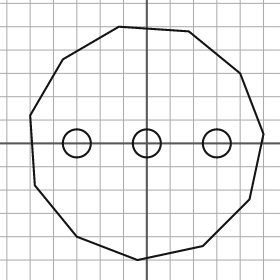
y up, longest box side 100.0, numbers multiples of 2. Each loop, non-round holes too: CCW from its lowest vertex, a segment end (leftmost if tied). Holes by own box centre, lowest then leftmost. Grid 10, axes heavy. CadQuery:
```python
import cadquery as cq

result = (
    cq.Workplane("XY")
    .moveTo(-4.0, -50.0)
    .lineTo(24.0, -44.0)
    .lineTo(44.0, -24.0)
    .lineTo(50.0, 4.0)
    .lineTo(40.0, 30.0)
    .lineTo(18.0, 48.0)
    .lineTo(-12.0, 50.0)
    .lineTo(-36.0, 36.0)
    .lineTo(-50.0, 12.0)
    .lineTo(-48.0, -18.0)
    .lineTo(-30.0, -40.0)
    .close()
    .moveTo(-30.0, 0.0)
    .circle(6.0)
    .moveTo(0.0, 0.0)
    .circle(6.0)
    .moveTo(30.0, 0.0)
    .circle(6.0)
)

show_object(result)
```